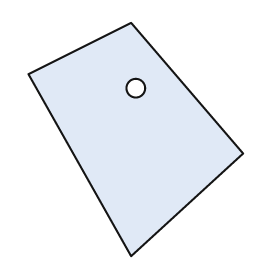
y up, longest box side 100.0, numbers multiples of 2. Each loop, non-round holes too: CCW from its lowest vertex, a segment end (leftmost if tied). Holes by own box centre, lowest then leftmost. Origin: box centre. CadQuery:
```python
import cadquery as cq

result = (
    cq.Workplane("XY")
    .moveTo(-2.0, -50.0)
    .lineTo(46.0, -6.0)
    .lineTo(-2.0, 50.0)
    .lineTo(-46.0, 28.0)
    .close()
    .moveTo(0.0, 22.0)
    .circle(4.0)
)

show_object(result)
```